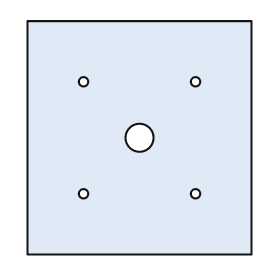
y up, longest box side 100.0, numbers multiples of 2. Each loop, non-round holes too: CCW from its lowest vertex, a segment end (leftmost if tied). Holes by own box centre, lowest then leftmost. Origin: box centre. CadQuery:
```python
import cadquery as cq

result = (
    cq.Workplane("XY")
    .moveTo(-48.0, -50.0)
    .lineTo(48.0, -50.0)
    .lineTo(48.0, 50.0)
    .lineTo(-48.0, 50.0)
    .close()
    .moveTo(-24.0, -24.0)
    .circle(2.0)
    .moveTo(24.0, -24.0)
    .circle(2.0)
    .moveTo(0.0, 0.0)
    .circle(6.0)
    .moveTo(-24.0, 24.0)
    .circle(2.0)
    .moveTo(24.0, 24.0)
    .circle(2.0)
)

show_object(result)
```